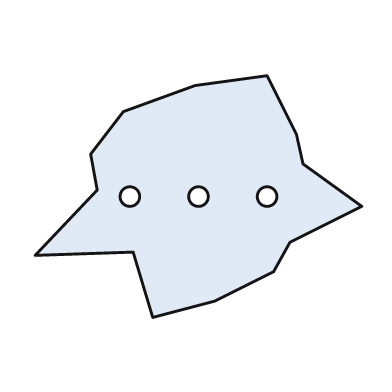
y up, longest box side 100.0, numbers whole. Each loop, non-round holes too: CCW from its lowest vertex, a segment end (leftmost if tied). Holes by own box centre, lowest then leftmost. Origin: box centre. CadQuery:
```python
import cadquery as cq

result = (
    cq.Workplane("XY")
    .moveTo(-14.0, -37.0)
    .lineTo(5.0, -32.0)
    .lineTo(23.0, -23.0)
    .lineTo(28.0, -14.0)
    .lineTo(50.0, -3.0)
    .lineTo(32.0, 10.0)
    .lineTo(30.0, 19.0)
    .lineTo(21.0, 37.0)
    .lineTo(-1.0, 34.0)
    .lineTo(-23.0, 26.0)
    .lineTo(-33.0, 13.0)
    .lineTo(-31.0, 2.0)
    .lineTo(-50.0, -18.0)
    .lineTo(-20.0, -17.0)
    .close()
    .moveTo(-21.0, 0.0)
    .circle(3.0)
    .moveTo(0.0, 0.0)
    .circle(3.0)
    .moveTo(21.0, 0.0)
    .circle(3.0)
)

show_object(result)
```